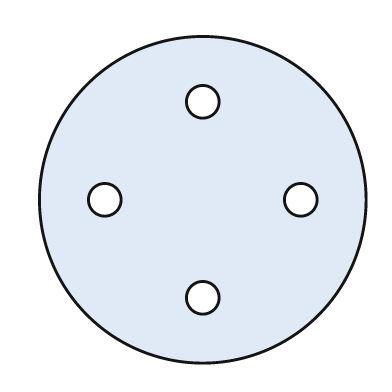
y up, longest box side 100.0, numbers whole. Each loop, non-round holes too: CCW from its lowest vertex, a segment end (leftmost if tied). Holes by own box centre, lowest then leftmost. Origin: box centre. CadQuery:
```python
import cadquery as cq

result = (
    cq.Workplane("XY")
    .moveTo(0.0, 0.0)
    .circle(50.0)
    .moveTo(0.0, -30.0)
    .circle(5.0)
    .moveTo(-30.0, 0.0)
    .circle(5.0)
    .moveTo(30.0, 0.0)
    .circle(5.0)
    .moveTo(0.0, 30.0)
    .circle(5.0)
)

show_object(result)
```